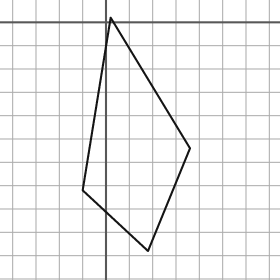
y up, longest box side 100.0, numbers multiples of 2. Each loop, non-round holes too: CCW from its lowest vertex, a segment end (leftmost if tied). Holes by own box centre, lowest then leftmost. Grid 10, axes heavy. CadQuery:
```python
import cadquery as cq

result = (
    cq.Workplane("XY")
    .moveTo(18.0, -98.0)
    .lineTo(36.0, -54.0)
    .lineTo(2.0, 2.0)
    .lineTo(-10.0, -72.0)
    .close()
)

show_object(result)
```